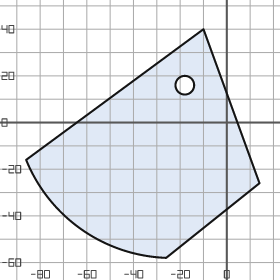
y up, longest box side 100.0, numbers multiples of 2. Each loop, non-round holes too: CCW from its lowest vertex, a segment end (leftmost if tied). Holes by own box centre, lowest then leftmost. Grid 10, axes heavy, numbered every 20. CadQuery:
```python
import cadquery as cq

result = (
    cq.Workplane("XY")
    .moveTo(-26.0, -58.0)
    .lineTo(14.0, -26.0)
    .lineTo(-10.0, 40.0)
    .lineTo(-86.0, -16.0)
    .threePointArc((-62.0, -46.0), (-26.0, -58.0))
    .close()
    .moveTo(-18.0, 16.0)
    .circle(4.0)
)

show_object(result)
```